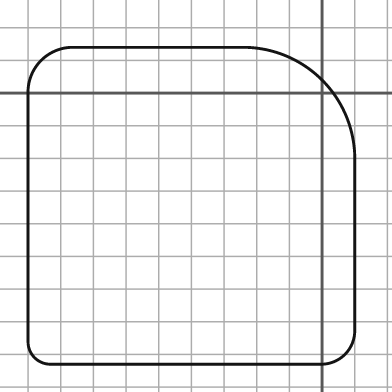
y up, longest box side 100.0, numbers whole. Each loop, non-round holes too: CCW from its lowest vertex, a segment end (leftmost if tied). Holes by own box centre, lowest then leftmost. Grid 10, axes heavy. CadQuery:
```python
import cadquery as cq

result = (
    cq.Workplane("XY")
    .moveTo(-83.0, -83.0)
    .lineTo(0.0, -83.0)
    .threePointArc((7.0, -80.0), (10.0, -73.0))
    .lineTo(10.0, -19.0)
    .threePointArc((0.0, 4.0), (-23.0, 14.0))
    .lineTo(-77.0, 14.0)
    .threePointArc((-86.0, 10.0), (-90.0, 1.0))
    .lineTo(-90.0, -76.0)
    .threePointArc((-88.0, -81.0), (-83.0, -83.0))
    .close()
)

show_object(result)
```